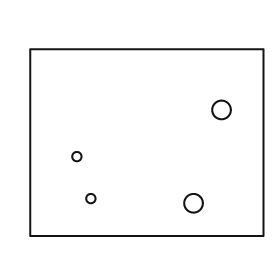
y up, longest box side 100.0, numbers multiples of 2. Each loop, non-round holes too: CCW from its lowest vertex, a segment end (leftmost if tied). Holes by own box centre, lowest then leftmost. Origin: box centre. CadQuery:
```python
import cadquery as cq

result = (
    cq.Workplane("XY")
    .moveTo(-50.0, -40.0)
    .lineTo(50.0, -40.0)
    .lineTo(50.0, 40.0)
    .lineTo(-50.0, 40.0)
    .close()
    .moveTo(20.0, -26.0)
    .circle(4.0)
    .moveTo(-24.0, -24.0)
    .circle(2.0)
    .moveTo(-30.0, -6.0)
    .circle(2.0)
    .moveTo(32.0, 14.0)
    .circle(4.0)
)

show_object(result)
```